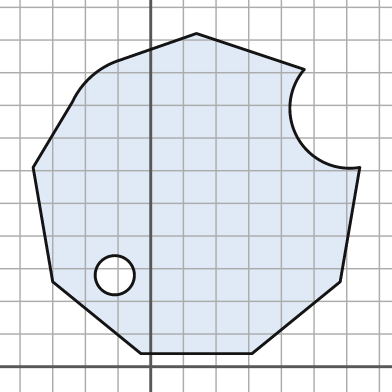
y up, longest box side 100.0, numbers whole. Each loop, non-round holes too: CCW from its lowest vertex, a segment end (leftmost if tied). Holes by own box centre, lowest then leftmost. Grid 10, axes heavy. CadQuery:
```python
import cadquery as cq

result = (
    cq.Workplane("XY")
    .moveTo(-3.0, 4.0)
    .lineTo(31.0, 4.0)
    .lineTo(58.0, 26.0)
    .lineTo(64.0, 61.0)
    .threePointArc((45.0, 70.0), (47.0, 91.0))
    .lineTo(14.0, 102.0)
    .lineTo(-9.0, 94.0)
    .threePointArc((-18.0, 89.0), (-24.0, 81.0))
    .lineTo(-36.0, 61.0)
    .lineTo(-30.0, 26.0)
    .close()
    .moveTo(-11.0, 28.0)
    .circle(6.0)
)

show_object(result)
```